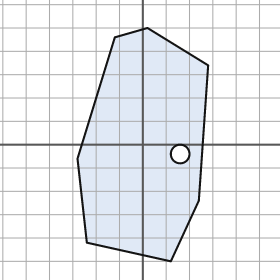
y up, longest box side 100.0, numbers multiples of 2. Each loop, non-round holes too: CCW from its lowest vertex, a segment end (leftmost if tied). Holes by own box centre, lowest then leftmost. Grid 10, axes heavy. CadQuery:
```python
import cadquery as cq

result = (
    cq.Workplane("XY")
    .moveTo(12.0, -50.0)
    .lineTo(24.0, -24.0)
    .lineTo(28.0, 34.0)
    .lineTo(2.0, 50.0)
    .lineTo(-12.0, 46.0)
    .lineTo(-28.0, -6.0)
    .lineTo(-24.0, -42.0)
    .close()
    .moveTo(16.0, -4.0)
    .circle(4.0)
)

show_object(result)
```